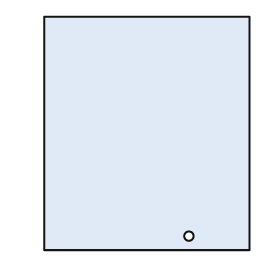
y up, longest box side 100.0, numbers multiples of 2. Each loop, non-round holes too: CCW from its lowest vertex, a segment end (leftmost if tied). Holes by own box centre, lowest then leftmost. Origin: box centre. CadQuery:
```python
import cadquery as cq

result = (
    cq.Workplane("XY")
    .moveTo(-44.0, -50.0)
    .lineTo(44.0, -50.0)
    .lineTo(44.0, 50.0)
    .lineTo(-44.0, 50.0)
    .close()
    .moveTo(18.0, -44.0)
    .circle(2.0)
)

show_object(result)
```